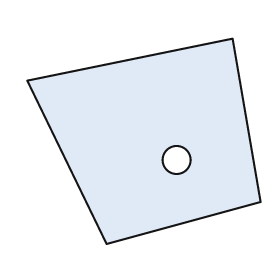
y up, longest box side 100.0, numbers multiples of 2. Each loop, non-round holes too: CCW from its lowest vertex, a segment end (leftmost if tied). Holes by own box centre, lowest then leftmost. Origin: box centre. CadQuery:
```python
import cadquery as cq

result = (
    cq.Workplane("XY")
    .moveTo(-16.0, -44.0)
    .lineTo(50.0, -26.0)
    .lineTo(38.0, 44.0)
    .lineTo(-50.0, 26.0)
    .close()
    .moveTo(14.0, -8.0)
    .circle(6.0)
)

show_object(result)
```